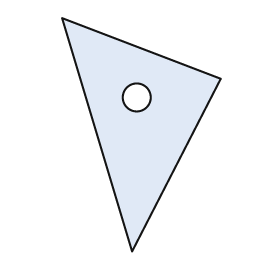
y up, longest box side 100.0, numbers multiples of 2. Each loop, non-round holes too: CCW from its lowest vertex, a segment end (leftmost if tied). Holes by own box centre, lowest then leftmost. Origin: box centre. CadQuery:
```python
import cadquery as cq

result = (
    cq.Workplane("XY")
    .moveTo(-4.0, -50.0)
    .lineTo(34.0, 24.0)
    .lineTo(-34.0, 50.0)
    .close()
    .moveTo(-2.0, 16.0)
    .circle(6.0)
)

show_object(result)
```